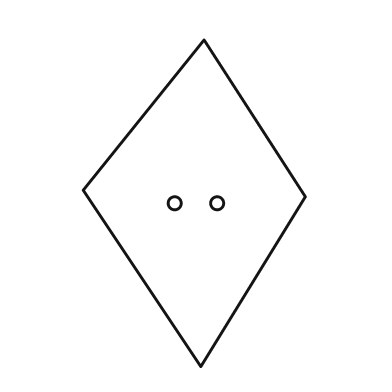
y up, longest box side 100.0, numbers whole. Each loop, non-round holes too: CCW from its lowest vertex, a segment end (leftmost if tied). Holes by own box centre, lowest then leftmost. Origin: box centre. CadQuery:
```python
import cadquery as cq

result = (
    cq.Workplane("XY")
    .moveTo(2.0, -50.0)
    .lineTo(34.0, 2.0)
    .lineTo(3.0, 50.0)
    .lineTo(-34.0, 4.0)
    .close()
    .moveTo(-6.0, 0.0)
    .circle(2.0)
    .moveTo(7.0, 0.0)
    .circle(2.0)
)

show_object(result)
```